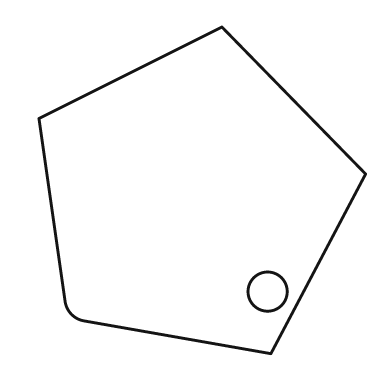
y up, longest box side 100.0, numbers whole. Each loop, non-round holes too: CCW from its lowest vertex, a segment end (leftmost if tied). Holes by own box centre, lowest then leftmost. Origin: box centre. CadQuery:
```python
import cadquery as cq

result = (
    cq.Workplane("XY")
    .moveTo(21.0, -50.0)
    .lineTo(50.0, 5.0)
    .lineTo(6.0, 50.0)
    .lineTo(-50.0, 22.0)
    .lineTo(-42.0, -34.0)
    .threePointArc((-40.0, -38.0), (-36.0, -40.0))
    .close()
    .moveTo(20.0, -31.0)
    .circle(6.0)
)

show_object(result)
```